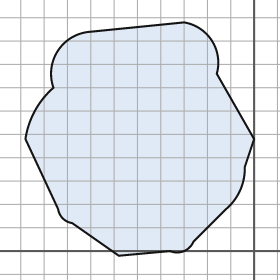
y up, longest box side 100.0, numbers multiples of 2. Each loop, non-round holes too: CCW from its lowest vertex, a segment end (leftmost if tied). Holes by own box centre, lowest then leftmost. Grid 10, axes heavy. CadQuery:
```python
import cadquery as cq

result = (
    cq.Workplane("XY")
    .moveTo(-58.0, -2.0)
    .lineTo(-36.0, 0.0)
    .threePointArc((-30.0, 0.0), (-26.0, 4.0))
    .lineTo(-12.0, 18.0)
    .threePointArc((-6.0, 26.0), (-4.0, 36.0))
    .lineTo(0.0, 48.0)
    .lineTo(-16.0, 76.0)
    .threePointArc((-18.0, 90.0), (-30.0, 98.0))
    .lineTo(-70.0, 94.0)
    .threePointArc((-84.0, 86.0), (-86.0, 70.0))
    .threePointArc((-94.0, 60.0), (-98.0, 48.0))
    .lineTo(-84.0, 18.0)
    .threePointArc((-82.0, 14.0), (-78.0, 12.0))
    .close()
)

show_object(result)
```